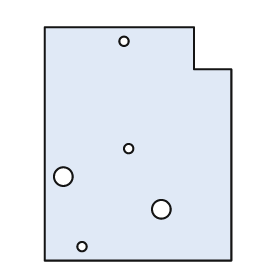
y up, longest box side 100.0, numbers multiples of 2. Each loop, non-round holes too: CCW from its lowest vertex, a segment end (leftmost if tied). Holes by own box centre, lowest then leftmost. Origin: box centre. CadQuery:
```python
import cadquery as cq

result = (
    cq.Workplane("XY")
    .moveTo(-40.0, -50.0)
    .lineTo(40.0, -50.0)
    .lineTo(40.0, 32.0)
    .lineTo(24.0, 32.0)
    .lineTo(24.0, 50.0)
    .lineTo(-40.0, 50.0)
    .close()
    .moveTo(-24.0, -44.0)
    .circle(2.0)
    .moveTo(10.0, -28.0)
    .circle(4.0)
    .moveTo(-32.0, -14.0)
    .circle(4.0)
    .moveTo(-4.0, -2.0)
    .circle(2.0)
    .moveTo(-6.0, 44.0)
    .circle(2.0)
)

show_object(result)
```